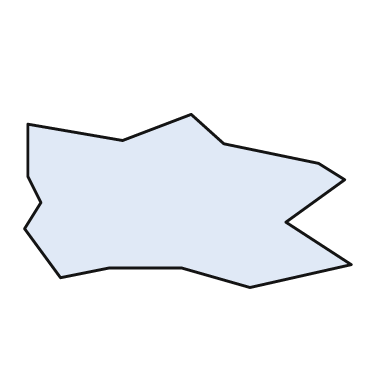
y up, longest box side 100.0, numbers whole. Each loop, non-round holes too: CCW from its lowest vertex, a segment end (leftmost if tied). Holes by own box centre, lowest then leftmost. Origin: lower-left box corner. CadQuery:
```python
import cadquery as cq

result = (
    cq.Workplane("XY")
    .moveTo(69.0, 0.0)
    .lineTo(100.0, 7.0)
    .lineTo(80.0, 20.0)
    .lineTo(98.0, 33.0)
    .lineTo(90.0, 38.0)
    .lineTo(61.0, 44.0)
    .lineTo(51.0, 53.0)
    .lineTo(30.0, 45.0)
    .lineTo(1.0, 50.0)
    .lineTo(1.0, 34.0)
    .lineTo(5.0, 26.0)
    .lineTo(0.0, 18.0)
    .lineTo(11.0, 3.0)
    .lineTo(26.0, 6.0)
    .lineTo(48.0, 6.0)
    .close()
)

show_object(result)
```